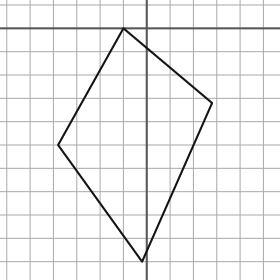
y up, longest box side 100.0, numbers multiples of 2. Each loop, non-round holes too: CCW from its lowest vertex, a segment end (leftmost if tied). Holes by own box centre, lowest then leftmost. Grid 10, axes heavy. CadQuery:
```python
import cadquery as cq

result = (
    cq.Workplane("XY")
    .moveTo(-2.0, -100.0)
    .lineTo(28.0, -32.0)
    .lineTo(-10.0, 0.0)
    .lineTo(-38.0, -50.0)
    .close()
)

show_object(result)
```